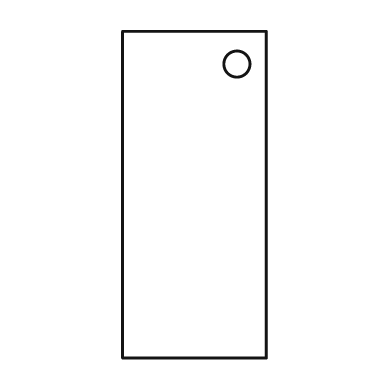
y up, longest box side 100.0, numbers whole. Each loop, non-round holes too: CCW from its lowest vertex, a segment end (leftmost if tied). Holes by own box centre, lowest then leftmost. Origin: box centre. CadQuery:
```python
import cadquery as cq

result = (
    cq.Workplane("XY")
    .moveTo(-22.0, -50.0)
    .lineTo(22.0, -50.0)
    .lineTo(22.0, 50.0)
    .lineTo(-22.0, 50.0)
    .close()
    .moveTo(13.0, 40.0)
    .circle(4.0)
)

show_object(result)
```